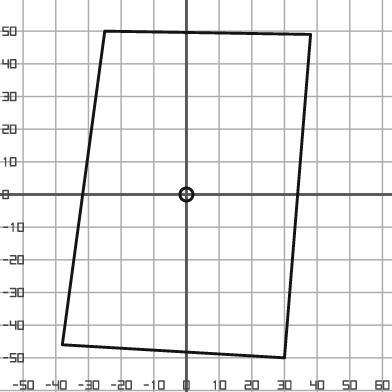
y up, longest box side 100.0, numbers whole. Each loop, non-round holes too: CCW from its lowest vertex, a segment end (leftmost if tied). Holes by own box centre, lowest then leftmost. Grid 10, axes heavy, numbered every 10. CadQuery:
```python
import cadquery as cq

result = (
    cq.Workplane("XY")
    .moveTo(30.0, -50.0)
    .lineTo(38.0, 49.0)
    .lineTo(-25.0, 50.0)
    .lineTo(-38.0, -46.0)
    .close()
    .moveTo(0.0, 0.0)
    .circle(2.0)
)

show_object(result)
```